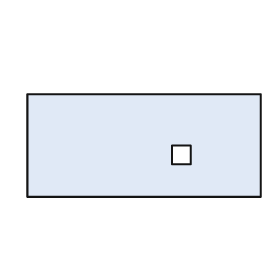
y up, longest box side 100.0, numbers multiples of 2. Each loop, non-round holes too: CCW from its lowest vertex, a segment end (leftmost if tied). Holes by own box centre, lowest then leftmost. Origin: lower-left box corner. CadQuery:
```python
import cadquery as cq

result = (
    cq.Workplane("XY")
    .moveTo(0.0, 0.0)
    .lineTo(100.0, 0.0)
    .lineTo(100.0, 44.0)
    .lineTo(0.0, 44.0)
    .close()
    .moveTo(62.0, 14.0)
    .lineTo(70.0, 14.0)
    .lineTo(70.0, 22.0)
    .lineTo(62.0, 22.0)
    .close()
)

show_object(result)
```